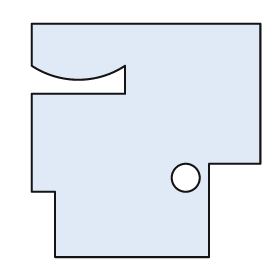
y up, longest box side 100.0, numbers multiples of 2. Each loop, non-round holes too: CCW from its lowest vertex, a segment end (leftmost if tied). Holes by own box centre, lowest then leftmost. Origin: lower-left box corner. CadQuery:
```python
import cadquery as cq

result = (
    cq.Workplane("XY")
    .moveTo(10.0, 0.0)
    .lineTo(76.0, 0.0)
    .lineTo(76.0, 40.0)
    .lineTo(98.0, 40.0)
    .lineTo(98.0, 100.0)
    .lineTo(0.0, 100.0)
    .lineTo(0.0, 82.0)
    .threePointArc((20.0, 76.0), (40.0, 82.0))
    .lineTo(40.0, 70.0)
    .lineTo(0.0, 70.0)
    .lineTo(0.0, 28.0)
    .lineTo(10.0, 28.0)
    .close()
    .moveTo(66.0, 34.0)
    .circle(6.0)
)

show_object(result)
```